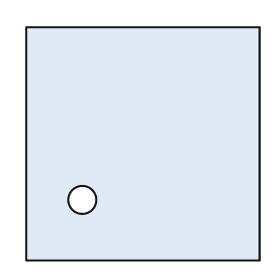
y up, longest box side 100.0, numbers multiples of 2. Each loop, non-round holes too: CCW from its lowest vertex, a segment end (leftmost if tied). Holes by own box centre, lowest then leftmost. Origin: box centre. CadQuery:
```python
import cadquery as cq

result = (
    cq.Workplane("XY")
    .moveTo(-50.0, -50.0)
    .lineTo(50.0, -50.0)
    .lineTo(50.0, 50.0)
    .lineTo(-50.0, 50.0)
    .close()
    .moveTo(-26.0, -24.0)
    .circle(6.0)
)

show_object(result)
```